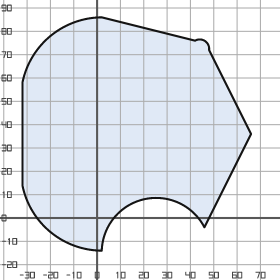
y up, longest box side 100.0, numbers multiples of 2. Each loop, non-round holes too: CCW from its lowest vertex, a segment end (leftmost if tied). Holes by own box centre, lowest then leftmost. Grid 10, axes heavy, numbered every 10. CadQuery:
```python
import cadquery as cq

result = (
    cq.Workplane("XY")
    .moveTo(2.0, -14.0)
    .threePointArc((20.0, 8.0), (46.0, -4.0))
    .lineTo(66.0, 36.0)
    .lineTo(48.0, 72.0)
    .threePointArc((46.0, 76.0), (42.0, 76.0))
    .lineTo(2.0, 86.0)
    .threePointArc((-20.0, 78.0), (-32.0, 58.0))
    .lineTo(-32.0, 14.0)
    .threePointArc((-20.0, -6.0), (2.0, -14.0))
    .close()
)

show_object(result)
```